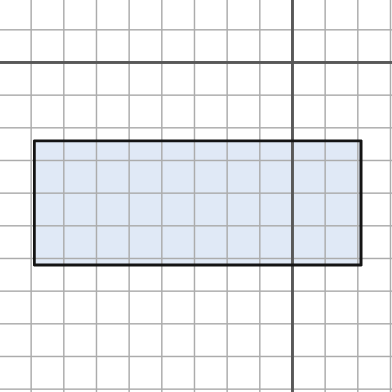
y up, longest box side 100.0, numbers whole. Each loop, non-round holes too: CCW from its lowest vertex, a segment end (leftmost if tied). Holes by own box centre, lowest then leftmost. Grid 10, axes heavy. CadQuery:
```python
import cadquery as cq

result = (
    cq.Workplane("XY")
    .moveTo(-79.0, -62.0)
    .lineTo(21.0, -62.0)
    .lineTo(21.0, -24.0)
    .lineTo(-79.0, -24.0)
    .close()
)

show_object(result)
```